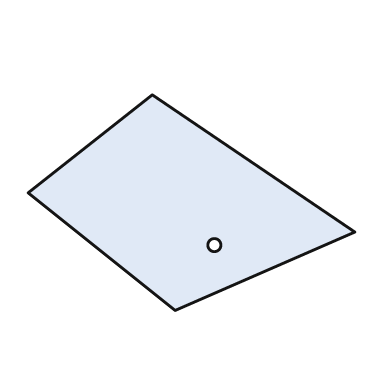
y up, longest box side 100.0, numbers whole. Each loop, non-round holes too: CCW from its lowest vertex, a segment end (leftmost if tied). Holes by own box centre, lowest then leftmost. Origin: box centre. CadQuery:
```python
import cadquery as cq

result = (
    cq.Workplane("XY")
    .moveTo(-5.0, -33.0)
    .lineTo(50.0, -9.0)
    .lineTo(-12.0, 33.0)
    .lineTo(-50.0, 3.0)
    .close()
    .moveTo(7.0, -13.0)
    .circle(2.0)
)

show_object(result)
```